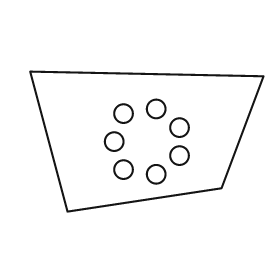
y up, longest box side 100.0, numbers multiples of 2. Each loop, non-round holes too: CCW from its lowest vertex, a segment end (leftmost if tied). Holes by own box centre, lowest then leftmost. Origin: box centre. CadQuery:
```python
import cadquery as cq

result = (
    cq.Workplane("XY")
    .moveTo(-34.0, -30.0)
    .lineTo(32.0, -20.0)
    .lineTo(50.0, 28.0)
    .lineTo(-50.0, 30.0)
    .close()
    .moveTo(4.0, -14.0)
    .circle(4.0)
    .moveTo(-10.0, -12.0)
    .circle(4.0)
    .moveTo(14.0, -6.0)
    .circle(4.0)
    .moveTo(-14.0, 0.0)
    .circle(4.0)
    .moveTo(14.0, 6.0)
    .circle(4.0)
    .moveTo(-10.0, 12.0)
    .circle(4.0)
    .moveTo(4.0, 14.0)
    .circle(4.0)
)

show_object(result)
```